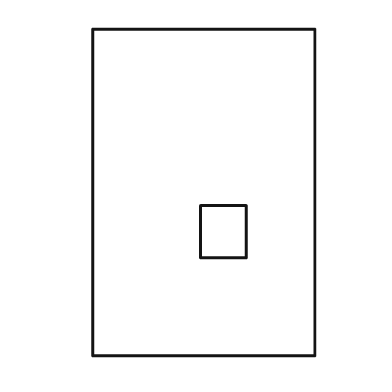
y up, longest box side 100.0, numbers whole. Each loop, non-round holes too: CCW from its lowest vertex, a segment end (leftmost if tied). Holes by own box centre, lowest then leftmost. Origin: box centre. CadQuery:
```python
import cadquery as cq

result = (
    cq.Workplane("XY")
    .moveTo(-34.0, -50.0)
    .lineTo(34.0, -50.0)
    .lineTo(34.0, 50.0)
    .lineTo(-34.0, 50.0)
    .close()
    .moveTo(-1.0, -20.0)
    .lineTo(13.0, -20.0)
    .lineTo(13.0, -4.0)
    .lineTo(-1.0, -4.0)
    .close()
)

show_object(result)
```